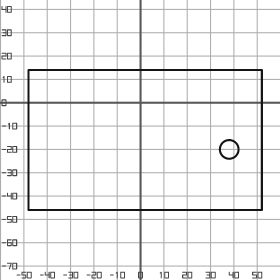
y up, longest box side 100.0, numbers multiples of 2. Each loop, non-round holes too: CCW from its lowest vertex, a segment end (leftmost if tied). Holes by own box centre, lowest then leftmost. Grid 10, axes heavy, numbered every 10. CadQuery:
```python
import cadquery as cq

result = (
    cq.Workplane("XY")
    .moveTo(-48.0, -46.0)
    .lineTo(52.0, -46.0)
    .lineTo(52.0, 14.0)
    .lineTo(-48.0, 14.0)
    .close()
    .moveTo(38.0, -20.0)
    .circle(4.0)
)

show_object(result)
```